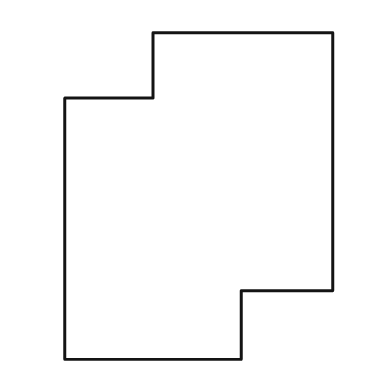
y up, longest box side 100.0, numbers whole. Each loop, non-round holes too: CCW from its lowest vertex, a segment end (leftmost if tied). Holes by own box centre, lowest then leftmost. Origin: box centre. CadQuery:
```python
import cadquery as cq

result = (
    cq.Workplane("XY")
    .moveTo(-41.0, -50.0)
    .lineTo(13.0, -50.0)
    .lineTo(13.0, -29.0)
    .lineTo(41.0, -29.0)
    .lineTo(41.0, 50.0)
    .lineTo(-14.0, 50.0)
    .lineTo(-14.0, 30.0)
    .lineTo(-41.0, 30.0)
    .close()
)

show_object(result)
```